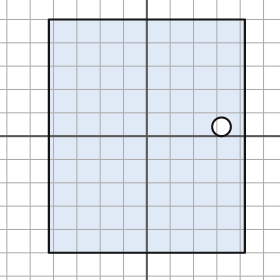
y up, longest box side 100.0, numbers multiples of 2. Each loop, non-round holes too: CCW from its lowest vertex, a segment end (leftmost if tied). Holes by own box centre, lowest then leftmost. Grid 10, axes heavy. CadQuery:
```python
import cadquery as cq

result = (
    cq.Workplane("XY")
    .moveTo(-42.0, -50.0)
    .lineTo(42.0, -50.0)
    .lineTo(42.0, 50.0)
    .lineTo(-42.0, 50.0)
    .close()
    .moveTo(32.0, 4.0)
    .circle(4.0)
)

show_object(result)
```